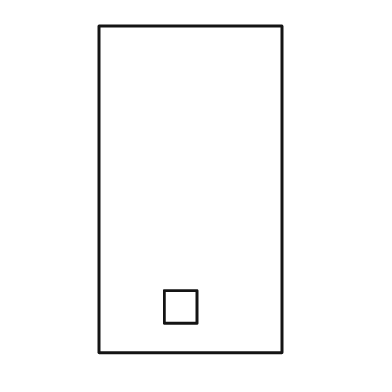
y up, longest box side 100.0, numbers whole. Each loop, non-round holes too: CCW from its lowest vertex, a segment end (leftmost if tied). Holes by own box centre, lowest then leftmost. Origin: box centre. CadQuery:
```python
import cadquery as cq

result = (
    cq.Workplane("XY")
    .moveTo(-28.0, -50.0)
    .lineTo(28.0, -50.0)
    .lineTo(28.0, 50.0)
    .lineTo(-28.0, 50.0)
    .close()
    .moveTo(-8.0, -41.0)
    .lineTo(2.0, -41.0)
    .lineTo(2.0, -31.0)
    .lineTo(-8.0, -31.0)
    .close()
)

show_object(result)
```